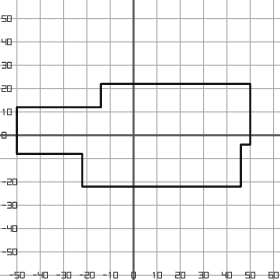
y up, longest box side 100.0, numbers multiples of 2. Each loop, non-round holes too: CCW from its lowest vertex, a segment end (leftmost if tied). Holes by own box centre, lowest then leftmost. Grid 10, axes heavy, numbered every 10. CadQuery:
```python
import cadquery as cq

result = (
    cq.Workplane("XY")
    .moveTo(-22.0, -22.0)
    .lineTo(46.0, -22.0)
    .lineTo(46.0, -4.0)
    .lineTo(50.0, -4.0)
    .lineTo(50.0, 22.0)
    .lineTo(-14.0, 22.0)
    .lineTo(-14.0, 12.0)
    .lineTo(-50.0, 12.0)
    .lineTo(-50.0, -8.0)
    .lineTo(-22.0, -8.0)
    .close()
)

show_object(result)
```